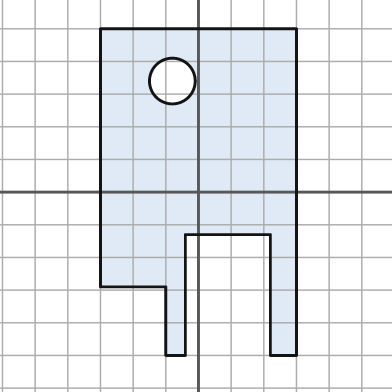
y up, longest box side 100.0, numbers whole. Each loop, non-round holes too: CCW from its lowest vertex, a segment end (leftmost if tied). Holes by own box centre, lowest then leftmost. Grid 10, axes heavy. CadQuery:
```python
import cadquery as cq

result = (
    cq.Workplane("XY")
    .moveTo(-10.0, -50.0)
    .lineTo(-4.0, -50.0)
    .lineTo(-4.0, -13.0)
    .lineTo(22.0, -13.0)
    .lineTo(22.0, -50.0)
    .lineTo(30.0, -50.0)
    .lineTo(30.0, 50.0)
    .lineTo(-30.0, 50.0)
    .lineTo(-30.0, -29.0)
    .lineTo(-10.0, -29.0)
    .close()
    .moveTo(-8.0, 34.0)
    .circle(7.0)
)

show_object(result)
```